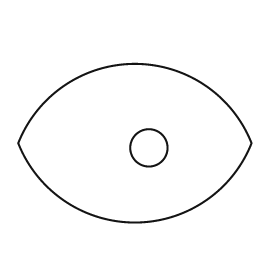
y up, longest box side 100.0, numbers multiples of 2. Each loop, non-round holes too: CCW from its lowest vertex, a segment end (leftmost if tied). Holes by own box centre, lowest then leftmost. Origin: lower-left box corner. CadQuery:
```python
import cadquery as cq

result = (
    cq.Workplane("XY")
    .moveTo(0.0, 34.0)
    .threePointArc((50.0, 0.0), (100.0, 34.0))
    .threePointArc((50.0, 68.0), (0.0, 34.0))
    .close()
    .moveTo(56.0, 32.0)
    .circle(8.0)
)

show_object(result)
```